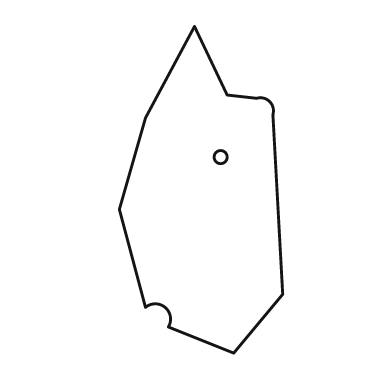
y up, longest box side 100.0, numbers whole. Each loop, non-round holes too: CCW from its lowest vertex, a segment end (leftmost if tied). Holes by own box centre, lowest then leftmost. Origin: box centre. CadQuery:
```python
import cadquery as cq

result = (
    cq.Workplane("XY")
    .moveTo(10.0, -50.0)
    .lineTo(25.0, -32.0)
    .lineTo(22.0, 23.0)
    .threePointArc((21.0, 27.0), (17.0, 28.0))
    .lineTo(8.0, 29.0)
    .lineTo(-2.0, 50.0)
    .lineTo(-17.0, 22.0)
    .lineTo(-25.0, -6.0)
    .lineTo(-17.0, -36.0)
    .threePointArc((-11.0, -36.0), (-10.0, -42.0))
    .close()
    .moveTo(6.0, 10.0)
    .circle(2.0)
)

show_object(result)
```